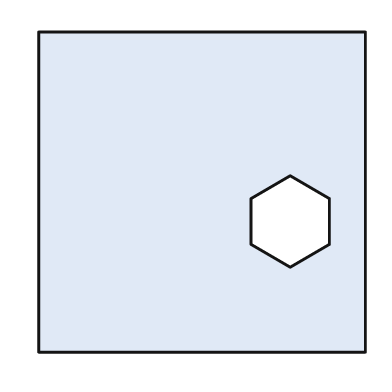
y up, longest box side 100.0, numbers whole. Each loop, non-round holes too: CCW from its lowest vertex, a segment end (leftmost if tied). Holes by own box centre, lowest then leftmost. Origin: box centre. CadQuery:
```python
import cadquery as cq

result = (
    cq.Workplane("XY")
    .moveTo(-50.0, -49.0)
    .lineTo(50.0, -49.0)
    .lineTo(50.0, 49.0)
    .lineTo(-50.0, 49.0)
    .close()
    .moveTo(27.0, -23.0)
    .lineTo(39.0, -16.0)
    .lineTo(39.0, -2.0)
    .lineTo(27.0, 5.0)
    .lineTo(15.0, -2.0)
    .lineTo(15.0, -16.0)
    .close()
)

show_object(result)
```